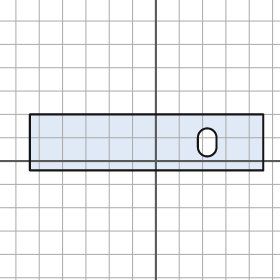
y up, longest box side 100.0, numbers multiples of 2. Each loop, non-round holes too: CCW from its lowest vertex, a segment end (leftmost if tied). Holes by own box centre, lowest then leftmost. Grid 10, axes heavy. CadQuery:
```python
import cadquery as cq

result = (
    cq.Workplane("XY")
    .moveTo(-54.0, -4.0)
    .lineTo(46.0, -4.0)
    .lineTo(46.0, 20.0)
    .lineTo(-54.0, 20.0)
    .close()
    .moveTo(18.0, 6.0)
    .threePointArc((22.0, 2.0), (26.0, 6.0))
    .lineTo(26.0, 10.0)
    .threePointArc((22.0, 14.0), (18.0, 10.0))
    .close()
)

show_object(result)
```